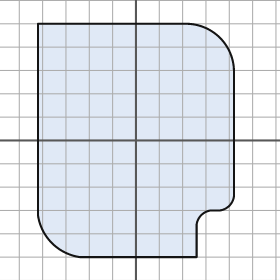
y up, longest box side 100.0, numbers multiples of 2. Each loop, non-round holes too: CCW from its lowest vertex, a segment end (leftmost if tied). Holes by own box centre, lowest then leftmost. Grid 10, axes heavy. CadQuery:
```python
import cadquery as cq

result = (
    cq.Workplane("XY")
    .moveTo(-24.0, -50.0)
    .lineTo(26.0, -50.0)
    .lineTo(26.0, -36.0)
    .threePointArc((28.0, -32.0), (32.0, -30.0))
    .lineTo(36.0, -30.0)
    .threePointArc((40.0, -28.0), (42.0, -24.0))
    .lineTo(42.0, 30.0)
    .threePointArc((36.0, 44.0), (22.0, 50.0))
    .lineTo(-42.0, 50.0)
    .lineTo(-42.0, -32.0)
    .threePointArc((-36.0, -44.0), (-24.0, -50.0))
    .close()
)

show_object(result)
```